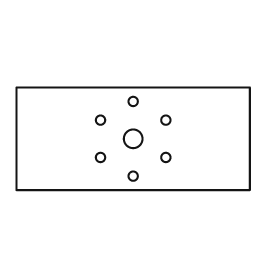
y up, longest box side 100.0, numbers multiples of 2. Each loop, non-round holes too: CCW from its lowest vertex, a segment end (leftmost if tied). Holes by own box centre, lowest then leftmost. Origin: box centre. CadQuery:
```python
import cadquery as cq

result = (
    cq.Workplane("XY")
    .moveTo(-50.0, -22.0)
    .lineTo(50.0, -22.0)
    .lineTo(50.0, 22.0)
    .lineTo(-50.0, 22.0)
    .close()
    .moveTo(0.0, -16.0)
    .circle(2.0)
    .moveTo(-14.0, -8.0)
    .circle(2.0)
    .moveTo(14.0, -8.0)
    .circle(2.0)
    .moveTo(0.0, 0.0)
    .circle(4.0)
    .moveTo(-14.0, 8.0)
    .circle(2.0)
    .moveTo(14.0, 8.0)
    .circle(2.0)
    .moveTo(0.0, 16.0)
    .circle(2.0)
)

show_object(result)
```